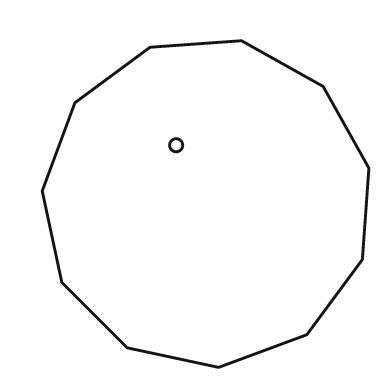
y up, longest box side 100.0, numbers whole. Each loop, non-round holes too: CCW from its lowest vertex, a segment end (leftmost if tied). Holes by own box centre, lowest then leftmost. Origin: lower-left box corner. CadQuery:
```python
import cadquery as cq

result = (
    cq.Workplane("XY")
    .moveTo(54.0, 0.0)
    .lineTo(81.0, 10.0)
    .lineTo(98.0, 33.0)
    .lineTo(100.0, 61.0)
    .lineTo(86.0, 86.0)
    .lineTo(61.0, 100.0)
    .lineTo(33.0, 98.0)
    .lineTo(10.0, 81.0)
    .lineTo(0.0, 54.0)
    .lineTo(6.0, 26.0)
    .lineTo(26.0, 6.0)
    .close()
    .moveTo(41.0, 68.0)
    .circle(2.0)
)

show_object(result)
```